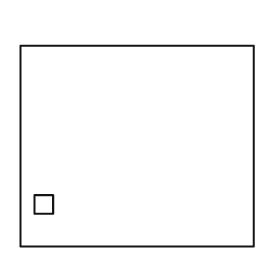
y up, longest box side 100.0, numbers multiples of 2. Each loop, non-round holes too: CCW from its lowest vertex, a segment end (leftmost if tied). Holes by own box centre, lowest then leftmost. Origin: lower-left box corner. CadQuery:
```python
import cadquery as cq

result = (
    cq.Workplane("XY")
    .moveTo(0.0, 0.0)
    .lineTo(100.0, 0.0)
    .lineTo(100.0, 86.0)
    .lineTo(0.0, 86.0)
    .close()
    .moveTo(6.0, 14.0)
    .lineTo(14.0, 14.0)
    .lineTo(14.0, 22.0)
    .lineTo(6.0, 22.0)
    .close()
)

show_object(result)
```